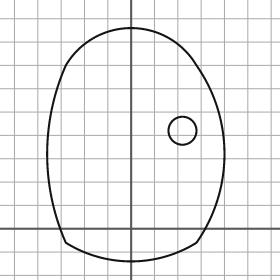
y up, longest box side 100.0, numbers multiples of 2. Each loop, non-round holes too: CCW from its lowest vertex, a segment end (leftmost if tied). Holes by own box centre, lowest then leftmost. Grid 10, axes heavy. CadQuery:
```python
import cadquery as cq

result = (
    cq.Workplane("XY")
    .moveTo(-28.0, -6.0)
    .threePointArc((0.0, -14.0), (28.0, -6.0))
    .threePointArc((40.0, 32.0), (28.0, 70.0))
    .threePointArc((0.0, 86.0), (-28.0, 70.0))
    .threePointArc((-36.0, 32.0), (-28.0, -6.0))
    .close()
    .moveTo(22.0, 42.0)
    .circle(6.0)
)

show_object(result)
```